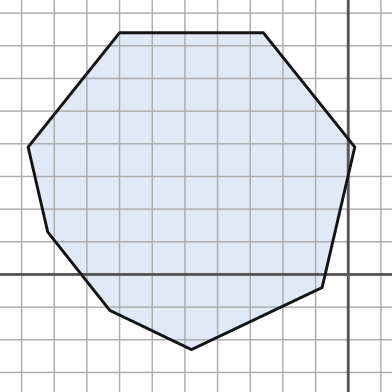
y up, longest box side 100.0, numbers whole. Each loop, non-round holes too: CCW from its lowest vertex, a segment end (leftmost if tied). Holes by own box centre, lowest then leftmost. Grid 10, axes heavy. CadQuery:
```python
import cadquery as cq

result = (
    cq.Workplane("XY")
    .moveTo(-48.0, -23.0)
    .lineTo(-8.0, -4.0)
    .lineTo(2.0, 39.0)
    .lineTo(-26.0, 74.0)
    .lineTo(-70.0, 74.0)
    .lineTo(-98.0, 39.0)
    .lineTo(-92.0, 13.0)
    .lineTo(-73.0, -11.0)
    .close()
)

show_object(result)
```